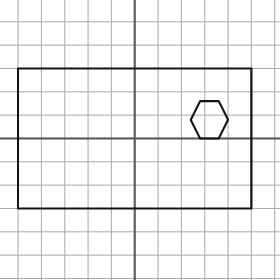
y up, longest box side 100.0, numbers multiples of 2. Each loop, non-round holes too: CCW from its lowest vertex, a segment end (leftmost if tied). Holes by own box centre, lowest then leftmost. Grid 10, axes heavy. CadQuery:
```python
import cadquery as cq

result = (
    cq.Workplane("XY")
    .moveTo(-50.0, -30.0)
    .lineTo(50.0, -30.0)
    .lineTo(50.0, 30.0)
    .lineTo(-50.0, 30.0)
    .close()
    .moveTo(28.0, 0.0)
    .lineTo(36.0, 0.0)
    .lineTo(40.0, 8.0)
    .lineTo(36.0, 16.0)
    .lineTo(28.0, 16.0)
    .lineTo(24.0, 8.0)
    .close()
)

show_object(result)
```